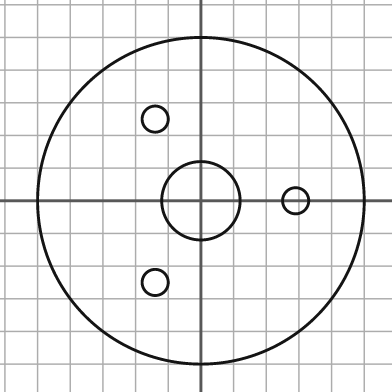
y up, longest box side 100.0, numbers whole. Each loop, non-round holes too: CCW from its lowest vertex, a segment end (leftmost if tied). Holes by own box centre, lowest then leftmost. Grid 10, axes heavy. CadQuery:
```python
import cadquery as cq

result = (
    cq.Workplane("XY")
    .moveTo(0.0, 0.0)
    .circle(50.0)
    .moveTo(-14.0, -25.0)
    .circle(4.0)
    .moveTo(0.0, 0.0)
    .circle(12.0)
    .moveTo(29.0, 0.0)
    .circle(4.0)
    .moveTo(-14.0, 25.0)
    .circle(4.0)
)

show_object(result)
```